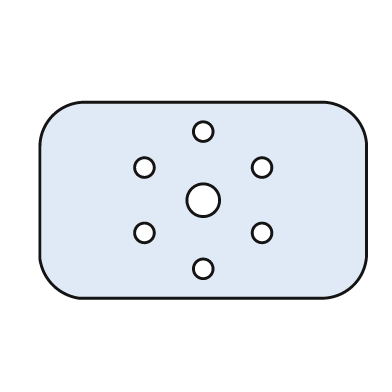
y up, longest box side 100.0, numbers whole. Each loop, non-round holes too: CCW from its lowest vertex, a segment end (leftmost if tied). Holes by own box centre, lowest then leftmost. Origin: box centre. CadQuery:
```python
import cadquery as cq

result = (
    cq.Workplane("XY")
    .moveTo(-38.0, -30.0)
    .lineTo(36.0, -30.0)
    .threePointArc((46.0, -26.0), (50.0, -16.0))
    .lineTo(50.0, 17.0)
    .threePointArc((46.0, 26.0), (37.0, 30.0))
    .lineTo(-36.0, 30.0)
    .threePointArc((-46.0, 26.0), (-50.0, 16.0))
    .lineTo(-50.0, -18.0)
    .threePointArc((-46.0, -26.0), (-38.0, -30.0))
    .close()
    .moveTo(0.0, -21.0)
    .circle(3.0)
    .moveTo(-18.0, -10.0)
    .circle(3.0)
    .moveTo(18.0, -10.0)
    .circle(3.0)
    .moveTo(0.0, 0.0)
    .circle(5.0)
    .moveTo(-18.0, 10.0)
    .circle(3.0)
    .moveTo(18.0, 10.0)
    .circle(3.0)
    .moveTo(0.0, 21.0)
    .circle(3.0)
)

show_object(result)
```